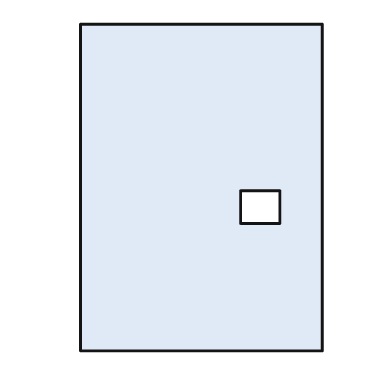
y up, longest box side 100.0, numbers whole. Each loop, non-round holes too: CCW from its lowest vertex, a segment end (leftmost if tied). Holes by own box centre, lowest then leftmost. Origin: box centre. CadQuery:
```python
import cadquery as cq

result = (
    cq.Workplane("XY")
    .moveTo(-37.0, -50.0)
    .lineTo(37.0, -50.0)
    .lineTo(37.0, 50.0)
    .lineTo(-37.0, 50.0)
    .close()
    .moveTo(12.0, -11.0)
    .lineTo(24.0, -11.0)
    .lineTo(24.0, -1.0)
    .lineTo(12.0, -1.0)
    .close()
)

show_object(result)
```